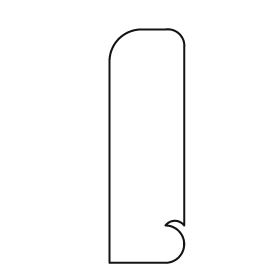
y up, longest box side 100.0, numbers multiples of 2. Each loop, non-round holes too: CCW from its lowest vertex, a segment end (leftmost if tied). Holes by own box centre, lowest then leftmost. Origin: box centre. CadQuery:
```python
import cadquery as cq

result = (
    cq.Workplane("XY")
    .moveTo(-16.0, -50.0)
    .lineTo(8.0, -50.0)
    .threePointArc((16.0, -42.0), (8.0, -34.0))
    .threePointArc((12.0, -32.0), (16.0, -34.0))
    .lineTo(16.0, 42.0)
    .threePointArc((14.0, 48.0), (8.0, 50.0))
    .lineTo(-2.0, 50.0)
    .threePointArc((-12.0, 46.0), (-16.0, 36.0))
    .close()
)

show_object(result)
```